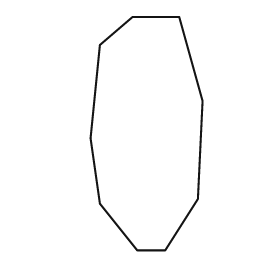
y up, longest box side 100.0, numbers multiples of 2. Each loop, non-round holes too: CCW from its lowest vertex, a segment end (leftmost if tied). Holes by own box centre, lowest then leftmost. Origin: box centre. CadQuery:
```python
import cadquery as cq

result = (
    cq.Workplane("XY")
    .moveTo(-4.0, -50.0)
    .lineTo(8.0, -50.0)
    .lineTo(22.0, -28.0)
    .lineTo(24.0, 14.0)
    .lineTo(14.0, 50.0)
    .lineTo(-6.0, 50.0)
    .lineTo(-20.0, 38.0)
    .lineTo(-24.0, -2.0)
    .lineTo(-20.0, -30.0)
    .close()
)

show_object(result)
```